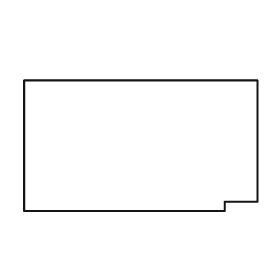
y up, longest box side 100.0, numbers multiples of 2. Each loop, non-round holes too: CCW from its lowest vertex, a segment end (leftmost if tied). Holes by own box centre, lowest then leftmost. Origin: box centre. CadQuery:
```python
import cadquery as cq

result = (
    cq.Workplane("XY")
    .moveTo(-50.0, -28.0)
    .lineTo(36.0, -28.0)
    .lineTo(36.0, -24.0)
    .lineTo(50.0, -24.0)
    .lineTo(50.0, 28.0)
    .lineTo(-50.0, 28.0)
    .close()
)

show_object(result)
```